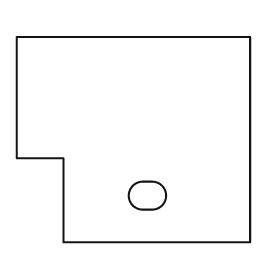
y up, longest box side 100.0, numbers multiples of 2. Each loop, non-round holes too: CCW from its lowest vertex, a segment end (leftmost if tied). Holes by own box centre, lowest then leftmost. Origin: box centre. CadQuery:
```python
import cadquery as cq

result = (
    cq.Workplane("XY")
    .moveTo(-30.0, -44.0)
    .lineTo(50.0, -44.0)
    .lineTo(50.0, 44.0)
    .lineTo(-50.0, 44.0)
    .lineTo(-50.0, -8.0)
    .lineTo(-30.0, -8.0)
    .close()
    .moveTo(4.0, -30.0)
    .lineTo(8.0, -30.0)
    .threePointArc((14.0, -24.0), (8.0, -18.0))
    .lineTo(4.0, -18.0)
    .threePointArc((-2.0, -24.0), (4.0, -30.0))
    .close()
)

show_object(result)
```